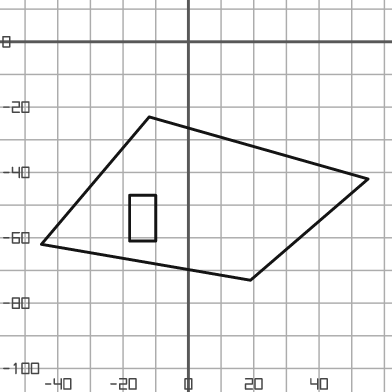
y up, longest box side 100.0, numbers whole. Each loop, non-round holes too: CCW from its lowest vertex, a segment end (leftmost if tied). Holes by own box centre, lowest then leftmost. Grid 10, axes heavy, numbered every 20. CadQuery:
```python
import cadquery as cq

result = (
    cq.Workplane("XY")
    .moveTo(19.0, -73.0)
    .lineTo(55.0, -42.0)
    .lineTo(-12.0, -23.0)
    .lineTo(-45.0, -62.0)
    .close()
    .moveTo(-18.0, -61.0)
    .lineTo(-10.0, -61.0)
    .lineTo(-10.0, -47.0)
    .lineTo(-18.0, -47.0)
    .close()
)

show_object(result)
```